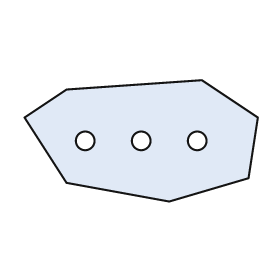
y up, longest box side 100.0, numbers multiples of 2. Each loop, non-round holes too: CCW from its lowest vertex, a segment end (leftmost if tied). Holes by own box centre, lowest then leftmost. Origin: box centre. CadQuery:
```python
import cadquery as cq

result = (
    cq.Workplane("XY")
    .moveTo(12.0, -26.0)
    .lineTo(46.0, -16.0)
    .lineTo(50.0, 10.0)
    .lineTo(26.0, 26.0)
    .lineTo(-32.0, 22.0)
    .lineTo(-50.0, 10.0)
    .lineTo(-32.0, -18.0)
    .close()
    .moveTo(-24.0, 0.0)
    .circle(4.0)
    .moveTo(0.0, 0.0)
    .circle(4.0)
    .moveTo(24.0, 0.0)
    .circle(4.0)
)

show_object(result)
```